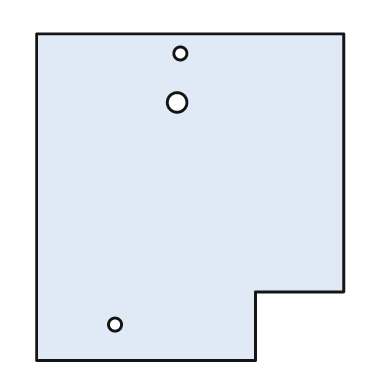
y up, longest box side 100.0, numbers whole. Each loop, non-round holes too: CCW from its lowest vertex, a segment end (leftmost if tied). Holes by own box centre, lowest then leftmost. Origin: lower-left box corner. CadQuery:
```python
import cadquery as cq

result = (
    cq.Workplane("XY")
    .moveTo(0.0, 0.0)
    .lineTo(67.0, 0.0)
    .lineTo(67.0, 21.0)
    .lineTo(94.0, 21.0)
    .lineTo(94.0, 100.0)
    .lineTo(0.0, 100.0)
    .close()
    .moveTo(24.0, 11.0)
    .circle(2.0)
    .moveTo(43.0, 79.0)
    .circle(3.0)
    .moveTo(44.0, 94.0)
    .circle(2.0)
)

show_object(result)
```